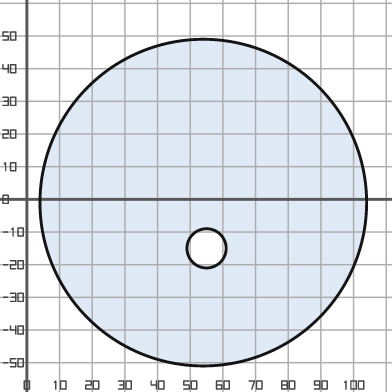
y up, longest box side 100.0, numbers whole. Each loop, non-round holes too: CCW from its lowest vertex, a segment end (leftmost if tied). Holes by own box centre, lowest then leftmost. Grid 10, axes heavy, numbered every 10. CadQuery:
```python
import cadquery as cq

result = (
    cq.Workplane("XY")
    .moveTo(54.0, -1.0)
    .circle(50.0)
    .moveTo(55.0, -15.0)
    .circle(6.0)
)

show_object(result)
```